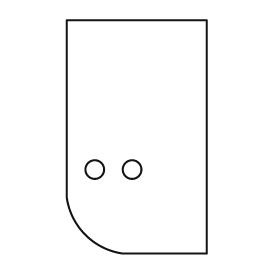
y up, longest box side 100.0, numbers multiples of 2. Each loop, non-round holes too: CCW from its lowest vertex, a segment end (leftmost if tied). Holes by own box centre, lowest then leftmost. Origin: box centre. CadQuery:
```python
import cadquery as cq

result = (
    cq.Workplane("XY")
    .moveTo(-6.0, -50.0)
    .lineTo(30.0, -50.0)
    .lineTo(30.0, 50.0)
    .lineTo(-30.0, 50.0)
    .lineTo(-30.0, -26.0)
    .threePointArc((-22.0, -42.0), (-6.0, -50.0))
    .close()
    .moveTo(-18.0, -14.0)
    .circle(4.0)
    .moveTo(-2.0, -14.0)
    .circle(4.0)
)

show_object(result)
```